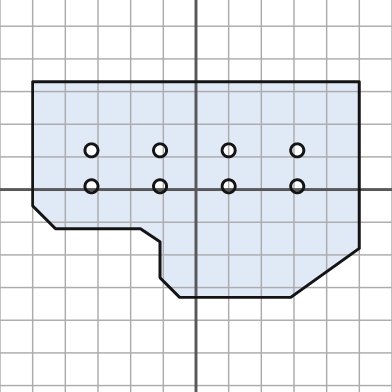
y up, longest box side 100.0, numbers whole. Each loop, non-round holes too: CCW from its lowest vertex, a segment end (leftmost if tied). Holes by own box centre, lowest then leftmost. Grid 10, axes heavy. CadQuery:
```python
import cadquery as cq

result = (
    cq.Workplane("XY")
    .moveTo(-5.0, -33.0)
    .lineTo(29.0, -33.0)
    .lineTo(50.0, -18.0)
    .lineTo(50.0, 33.0)
    .lineTo(-50.0, 33.0)
    .lineTo(-50.0, -5.0)
    .lineTo(-43.0, -12.0)
    .lineTo(-17.0, -12.0)
    .lineTo(-11.0, -16.0)
    .lineTo(-11.0, -27.0)
    .close()
    .moveTo(-32.0, 1.0)
    .circle(2.0)
    .moveTo(-11.0, 1.0)
    .circle(2.0)
    .moveTo(10.0, 1.0)
    .circle(2.0)
    .moveTo(31.0, 1.0)
    .circle(2.0)
    .moveTo(-32.0, 12.0)
    .circle(2.0)
    .moveTo(-11.0, 12.0)
    .circle(2.0)
    .moveTo(10.0, 12.0)
    .circle(2.0)
    .moveTo(31.0, 12.0)
    .circle(2.0)
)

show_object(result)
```